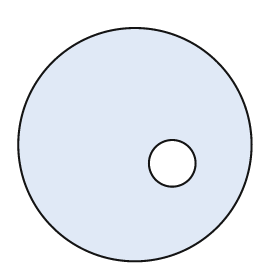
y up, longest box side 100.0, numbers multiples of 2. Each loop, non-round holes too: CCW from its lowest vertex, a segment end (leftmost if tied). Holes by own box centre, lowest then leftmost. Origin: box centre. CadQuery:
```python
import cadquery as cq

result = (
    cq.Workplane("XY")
    .moveTo(0.0, 0.0)
    .circle(50.0)
    .moveTo(16.0, -8.0)
    .circle(10.0)
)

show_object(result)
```